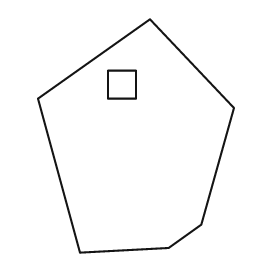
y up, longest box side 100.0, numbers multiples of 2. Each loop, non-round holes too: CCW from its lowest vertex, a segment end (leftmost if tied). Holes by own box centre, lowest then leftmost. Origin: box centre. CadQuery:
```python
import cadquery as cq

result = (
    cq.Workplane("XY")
    .moveTo(-24.0, -50.0)
    .lineTo(14.0, -48.0)
    .lineTo(28.0, -38.0)
    .lineTo(42.0, 12.0)
    .lineTo(6.0, 50.0)
    .lineTo(-42.0, 16.0)
    .close()
    .moveTo(-12.0, 16.0)
    .lineTo(0.0, 16.0)
    .lineTo(0.0, 28.0)
    .lineTo(-12.0, 28.0)
    .close()
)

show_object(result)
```